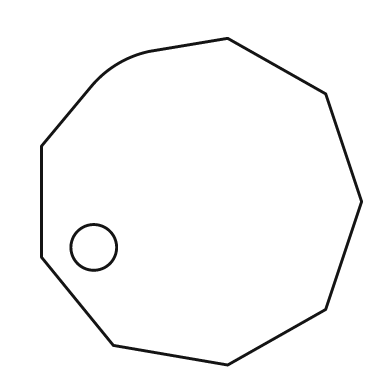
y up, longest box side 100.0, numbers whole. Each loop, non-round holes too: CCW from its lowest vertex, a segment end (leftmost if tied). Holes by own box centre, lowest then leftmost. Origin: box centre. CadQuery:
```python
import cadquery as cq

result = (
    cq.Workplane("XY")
    .moveTo(8.0, -50.0)
    .lineTo(38.0, -33.0)
    .lineTo(49.0, 0.0)
    .lineTo(38.0, 33.0)
    .lineTo(8.0, 50.0)
    .lineTo(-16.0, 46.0)
    .threePointArc((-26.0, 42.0), (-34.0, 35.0))
    .lineTo(-49.0, 17.0)
    .lineTo(-49.0, -17.0)
    .lineTo(-27.0, -44.0)
    .close()
    .moveTo(-33.0, -14.0)
    .circle(7.0)
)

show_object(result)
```